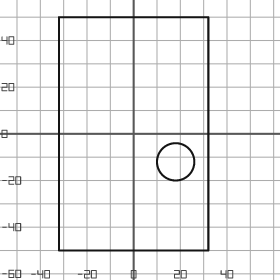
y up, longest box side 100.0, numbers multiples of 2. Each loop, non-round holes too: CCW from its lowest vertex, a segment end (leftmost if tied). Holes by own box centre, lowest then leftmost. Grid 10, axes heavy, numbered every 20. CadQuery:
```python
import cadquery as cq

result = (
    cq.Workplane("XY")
    .moveTo(-32.0, -50.0)
    .lineTo(32.0, -50.0)
    .lineTo(32.0, 50.0)
    .lineTo(-32.0, 50.0)
    .close()
    .moveTo(18.0, -12.0)
    .circle(8.0)
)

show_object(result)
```